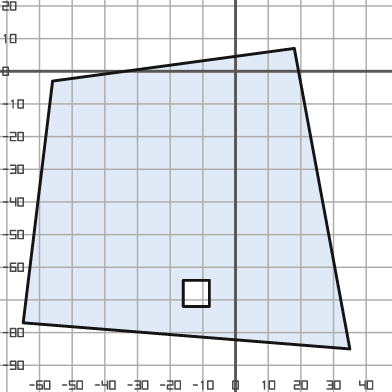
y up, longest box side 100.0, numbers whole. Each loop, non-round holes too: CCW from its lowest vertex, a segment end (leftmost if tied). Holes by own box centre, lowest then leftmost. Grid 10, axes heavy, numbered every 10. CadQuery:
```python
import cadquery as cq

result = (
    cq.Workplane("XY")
    .moveTo(35.0, -85.0)
    .lineTo(18.0, 7.0)
    .lineTo(-56.0, -3.0)
    .lineTo(-65.0, -77.0)
    .close()
    .moveTo(-16.0, -72.0)
    .lineTo(-8.0, -72.0)
    .lineTo(-8.0, -64.0)
    .lineTo(-16.0, -64.0)
    .close()
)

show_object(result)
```